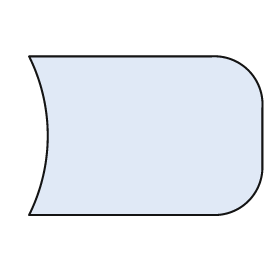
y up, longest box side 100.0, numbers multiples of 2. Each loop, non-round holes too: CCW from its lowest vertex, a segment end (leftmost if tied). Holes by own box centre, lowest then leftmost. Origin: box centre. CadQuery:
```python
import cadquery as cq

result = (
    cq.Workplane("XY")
    .moveTo(-50.0, -34.0)
    .lineTo(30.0, -34.0)
    .threePointArc((44.0, -28.0), (50.0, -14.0))
    .lineTo(50.0, 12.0)
    .threePointArc((44.0, 28.0), (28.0, 34.0))
    .lineTo(-50.0, 34.0)
    .threePointArc((-42.0, 0.0), (-50.0, -34.0))
    .close()
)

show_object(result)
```